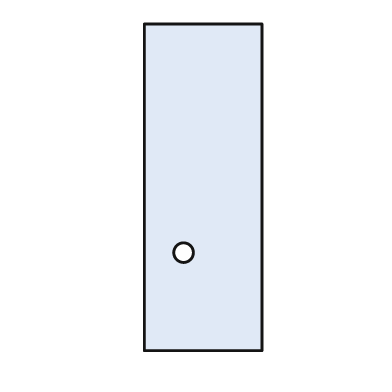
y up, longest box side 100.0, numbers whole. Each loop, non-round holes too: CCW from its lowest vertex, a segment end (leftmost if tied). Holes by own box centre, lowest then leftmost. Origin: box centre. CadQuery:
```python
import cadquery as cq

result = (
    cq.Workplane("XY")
    .moveTo(-18.0, -50.0)
    .lineTo(18.0, -50.0)
    .lineTo(18.0, 50.0)
    .lineTo(-18.0, 50.0)
    .close()
    .moveTo(-6.0, -20.0)
    .circle(3.0)
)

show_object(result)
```